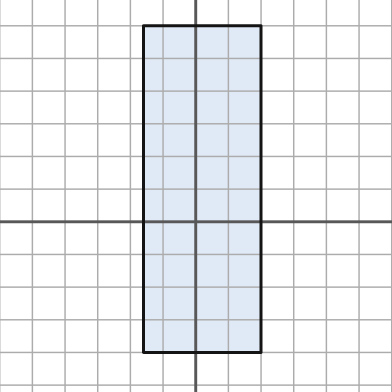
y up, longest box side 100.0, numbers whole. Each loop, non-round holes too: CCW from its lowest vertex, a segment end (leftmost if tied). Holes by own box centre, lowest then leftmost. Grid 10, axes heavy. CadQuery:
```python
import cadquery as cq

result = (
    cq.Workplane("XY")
    .moveTo(-16.0, -40.0)
    .lineTo(20.0, -40.0)
    .lineTo(20.0, 60.0)
    .lineTo(-16.0, 60.0)
    .close()
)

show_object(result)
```